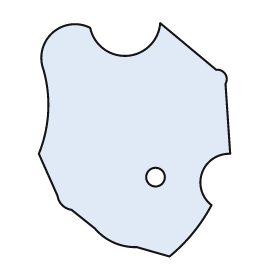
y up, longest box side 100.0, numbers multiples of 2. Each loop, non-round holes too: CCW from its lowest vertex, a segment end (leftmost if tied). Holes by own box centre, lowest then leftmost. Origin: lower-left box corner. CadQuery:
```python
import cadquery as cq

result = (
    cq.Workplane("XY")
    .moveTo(56.0, 0.0)
    .threePointArc((66.0, 10.0), (74.0, 22.0))
    .threePointArc((70.0, 36.0), (82.0, 44.0))
    .lineTo(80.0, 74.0)
    .threePointArc((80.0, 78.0), (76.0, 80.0))
    .lineTo(52.0, 100.0)
    .threePointArc((38.0, 86.0), (22.0, 98.0))
    .threePointArc((6.0, 96.0), (2.0, 80.0))
    .threePointArc((4.0, 62.0), (0.0, 44.0))
    .lineTo(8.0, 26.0)
    .threePointArc((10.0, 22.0), (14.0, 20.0))
    .lineTo(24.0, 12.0)
    .threePointArc((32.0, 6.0), (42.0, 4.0))
    .close()
    .moveTo(50.0, 34.0)
    .circle(4.0)
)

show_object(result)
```